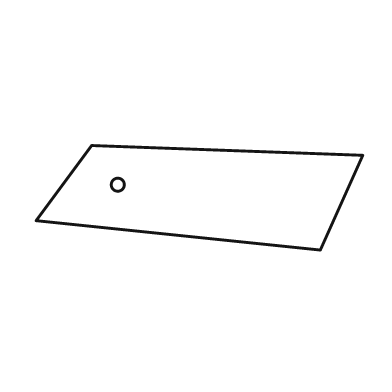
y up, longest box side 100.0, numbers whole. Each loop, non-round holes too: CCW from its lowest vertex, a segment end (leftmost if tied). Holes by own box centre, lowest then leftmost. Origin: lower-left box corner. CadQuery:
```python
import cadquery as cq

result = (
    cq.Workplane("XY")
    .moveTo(87.0, 0.0)
    .lineTo(100.0, 29.0)
    .lineTo(17.0, 32.0)
    .lineTo(0.0, 9.0)
    .close()
    .moveTo(25.0, 20.0)
    .circle(2.0)
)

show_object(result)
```